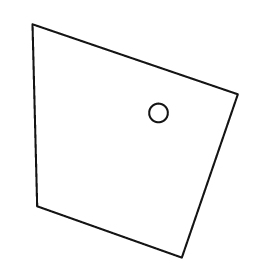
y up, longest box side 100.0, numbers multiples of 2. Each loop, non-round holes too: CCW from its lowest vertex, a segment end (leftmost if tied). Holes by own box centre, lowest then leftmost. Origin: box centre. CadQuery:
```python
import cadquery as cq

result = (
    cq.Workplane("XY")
    .moveTo(20.0, -50.0)
    .lineTo(44.0, 20.0)
    .lineTo(-44.0, 50.0)
    .lineTo(-42.0, -28.0)
    .close()
    .moveTo(10.0, 12.0)
    .circle(4.0)
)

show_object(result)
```